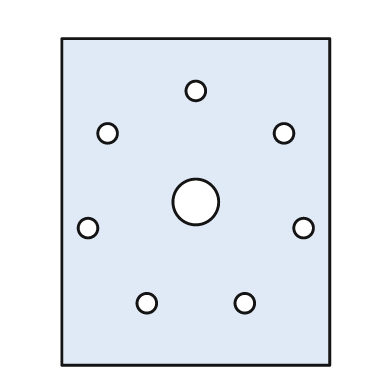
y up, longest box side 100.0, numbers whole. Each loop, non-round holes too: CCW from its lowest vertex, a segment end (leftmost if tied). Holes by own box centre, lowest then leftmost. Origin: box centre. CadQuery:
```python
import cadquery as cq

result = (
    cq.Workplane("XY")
    .moveTo(-41.0, -50.0)
    .lineTo(41.0, -50.0)
    .lineTo(41.0, 50.0)
    .lineTo(-41.0, 50.0)
    .close()
    .moveTo(-15.0, -31.0)
    .circle(3.0)
    .moveTo(15.0, -31.0)
    .circle(3.0)
    .moveTo(-33.0, -8.0)
    .circle(3.0)
    .moveTo(33.0, -8.0)
    .circle(3.0)
    .moveTo(0.0, 0.0)
    .circle(7.0)
    .moveTo(-27.0, 21.0)
    .circle(3.0)
    .moveTo(27.0, 21.0)
    .circle(3.0)
    .moveTo(0.0, 34.0)
    .circle(3.0)
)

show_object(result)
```